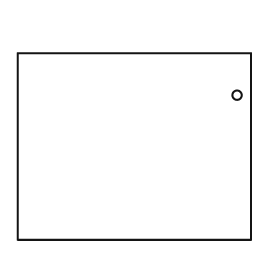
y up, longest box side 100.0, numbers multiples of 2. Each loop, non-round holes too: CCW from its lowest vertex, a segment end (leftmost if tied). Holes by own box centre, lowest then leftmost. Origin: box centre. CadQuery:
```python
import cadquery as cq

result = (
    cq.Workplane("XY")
    .moveTo(-50.0, -40.0)
    .lineTo(50.0, -40.0)
    .lineTo(50.0, 40.0)
    .lineTo(-50.0, 40.0)
    .close()
    .moveTo(44.0, 22.0)
    .circle(2.0)
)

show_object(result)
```